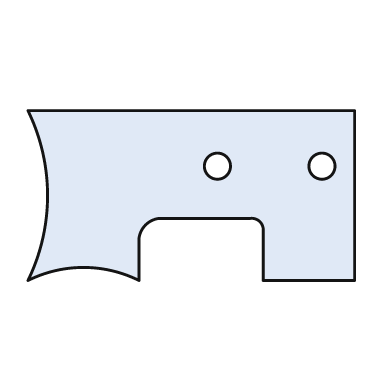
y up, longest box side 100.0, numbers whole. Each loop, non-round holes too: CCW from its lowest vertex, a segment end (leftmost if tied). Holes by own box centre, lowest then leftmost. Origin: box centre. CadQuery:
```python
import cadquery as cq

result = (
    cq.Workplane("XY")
    .moveTo(-50.0, -26.0)
    .threePointArc((-33.0, -22.0), (-16.0, -26.0))
    .lineTo(-16.0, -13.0)
    .threePointArc((-14.0, -9.0), (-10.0, -7.0))
    .lineTo(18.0, -7.0)
    .threePointArc((21.0, -8.0), (22.0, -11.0))
    .lineTo(22.0, -26.0)
    .lineTo(50.0, -26.0)
    .lineTo(50.0, 26.0)
    .lineTo(-50.0, 26.0)
    .threePointArc((-44.0, 0.0), (-50.0, -26.0))
    .close()
    .moveTo(8.0, 9.0)
    .circle(4.0)
    .moveTo(40.0, 9.0)
    .circle(4.0)
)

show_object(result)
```